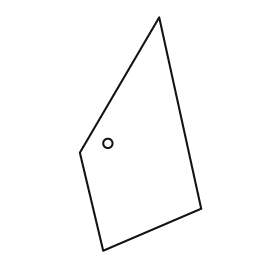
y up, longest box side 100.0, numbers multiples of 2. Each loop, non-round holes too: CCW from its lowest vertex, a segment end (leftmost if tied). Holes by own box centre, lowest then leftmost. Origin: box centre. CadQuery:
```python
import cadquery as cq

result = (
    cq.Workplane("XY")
    .moveTo(-16.0, -50.0)
    .lineTo(26.0, -32.0)
    .lineTo(8.0, 50.0)
    .lineTo(-26.0, -8.0)
    .close()
    .moveTo(-14.0, -4.0)
    .circle(2.0)
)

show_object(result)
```